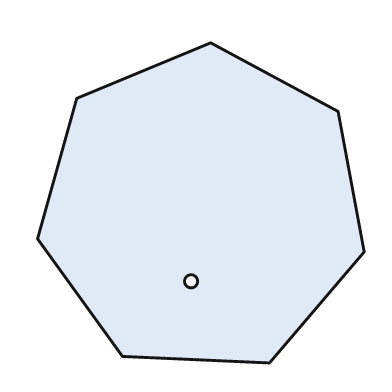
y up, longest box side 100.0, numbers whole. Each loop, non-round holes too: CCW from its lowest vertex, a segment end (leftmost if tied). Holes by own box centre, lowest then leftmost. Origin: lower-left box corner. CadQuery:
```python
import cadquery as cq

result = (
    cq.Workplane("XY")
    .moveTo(71.0, 0.0)
    .lineTo(100.0, 34.0)
    .lineTo(92.0, 77.0)
    .lineTo(53.0, 98.0)
    .lineTo(12.0, 81.0)
    .lineTo(0.0, 38.0)
    .lineTo(26.0, 2.0)
    .close()
    .moveTo(47.0, 25.0)
    .circle(2.0)
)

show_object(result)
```